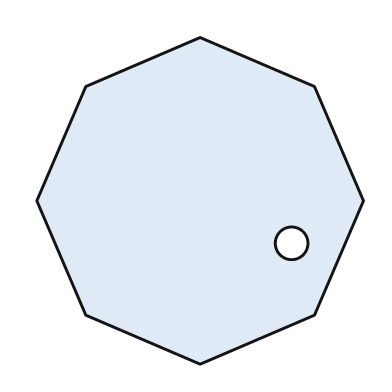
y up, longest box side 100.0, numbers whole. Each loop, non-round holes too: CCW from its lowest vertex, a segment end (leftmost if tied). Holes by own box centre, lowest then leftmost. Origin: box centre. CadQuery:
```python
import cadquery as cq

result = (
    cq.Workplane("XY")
    .moveTo(0.0, -50.0)
    .lineTo(35.0, -35.0)
    .lineTo(50.0, 0.0)
    .lineTo(35.0, 35.0)
    .lineTo(0.0, 50.0)
    .lineTo(-35.0, 35.0)
    .lineTo(-50.0, 0.0)
    .lineTo(-35.0, -35.0)
    .close()
    .moveTo(28.0, -13.0)
    .circle(5.0)
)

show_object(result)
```